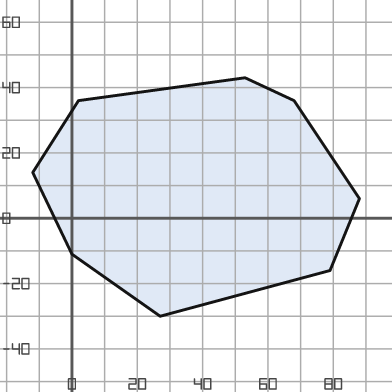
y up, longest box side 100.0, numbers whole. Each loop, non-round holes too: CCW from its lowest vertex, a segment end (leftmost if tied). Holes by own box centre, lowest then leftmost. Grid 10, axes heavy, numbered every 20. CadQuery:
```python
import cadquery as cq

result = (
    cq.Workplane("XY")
    .moveTo(27.0, -30.0)
    .lineTo(79.0, -16.0)
    .lineTo(88.0, 6.0)
    .lineTo(68.0, 36.0)
    .lineTo(53.0, 43.0)
    .lineTo(2.0, 36.0)
    .lineTo(-12.0, 14.0)
    .lineTo(0.0, -11.0)
    .close()
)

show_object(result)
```